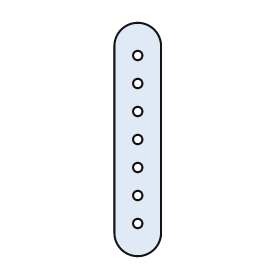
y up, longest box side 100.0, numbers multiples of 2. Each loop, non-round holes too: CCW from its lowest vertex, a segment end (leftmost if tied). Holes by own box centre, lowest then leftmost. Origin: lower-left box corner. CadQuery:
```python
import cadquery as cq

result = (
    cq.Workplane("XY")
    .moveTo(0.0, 10.0)
    .threePointArc((10.0, 0.0), (20.0, 10.0))
    .lineTo(20.0, 90.0)
    .threePointArc((10.0, 100.0), (0.0, 90.0))
    .close()
    .moveTo(10.0, 14.0)
    .circle(2.0)
    .moveTo(10.0, 26.0)
    .circle(2.0)
    .moveTo(10.0, 38.0)
    .circle(2.0)
    .moveTo(10.0, 50.0)
    .circle(2.0)
    .moveTo(10.0, 62.0)
    .circle(2.0)
    .moveTo(10.0, 74.0)
    .circle(2.0)
    .moveTo(10.0, 86.0)
    .circle(2.0)
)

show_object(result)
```